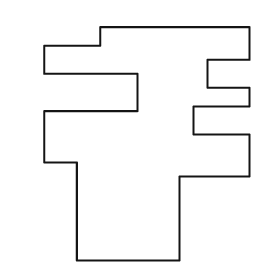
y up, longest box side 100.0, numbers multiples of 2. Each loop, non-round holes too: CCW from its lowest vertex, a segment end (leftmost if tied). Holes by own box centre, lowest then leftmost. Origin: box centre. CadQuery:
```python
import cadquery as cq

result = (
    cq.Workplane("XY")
    .moveTo(-30.0, -50.0)
    .lineTo(14.0, -50.0)
    .lineTo(14.0, -14.0)
    .lineTo(44.0, -14.0)
    .lineTo(44.0, 4.0)
    .lineTo(20.0, 4.0)
    .lineTo(20.0, 16.0)
    .lineTo(44.0, 16.0)
    .lineTo(44.0, 24.0)
    .lineTo(26.0, 24.0)
    .lineTo(26.0, 36.0)
    .lineTo(44.0, 36.0)
    .lineTo(44.0, 50.0)
    .lineTo(-20.0, 50.0)
    .lineTo(-20.0, 42.0)
    .lineTo(-44.0, 42.0)
    .lineTo(-44.0, 30.0)
    .lineTo(-4.0, 30.0)
    .lineTo(-4.0, 14.0)
    .lineTo(-44.0, 14.0)
    .lineTo(-44.0, -8.0)
    .lineTo(-30.0, -8.0)
    .close()
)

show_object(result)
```